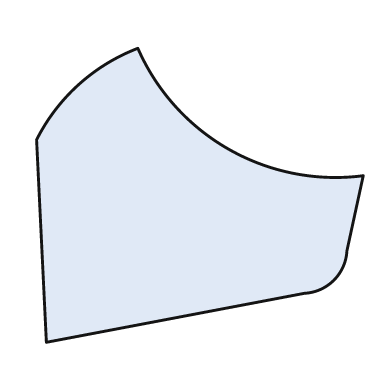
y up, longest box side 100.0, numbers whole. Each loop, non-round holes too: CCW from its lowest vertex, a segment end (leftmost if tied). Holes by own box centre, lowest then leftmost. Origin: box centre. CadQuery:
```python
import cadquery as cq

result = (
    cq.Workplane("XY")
    .moveTo(-47.0, -45.0)
    .lineTo(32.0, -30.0)
    .threePointArc((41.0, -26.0), (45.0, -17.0))
    .lineTo(50.0, 6.0)
    .threePointArc((9.0, 14.0), (-19.0, 45.0))
    .threePointArc((-37.0, 34.0), (-50.0, 17.0))
    .close()
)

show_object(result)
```